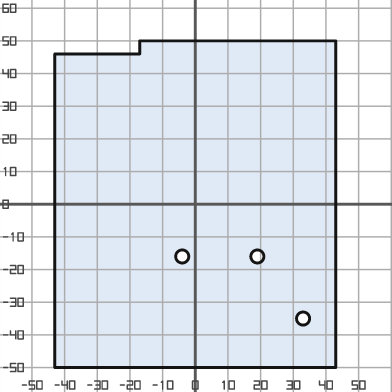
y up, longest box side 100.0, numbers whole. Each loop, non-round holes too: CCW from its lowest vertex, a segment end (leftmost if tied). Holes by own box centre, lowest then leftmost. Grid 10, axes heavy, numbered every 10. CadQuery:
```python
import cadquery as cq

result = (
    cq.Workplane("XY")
    .moveTo(-43.0, -50.0)
    .lineTo(43.0, -50.0)
    .lineTo(43.0, 50.0)
    .lineTo(-17.0, 50.0)
    .lineTo(-17.0, 46.0)
    .lineTo(-43.0, 46.0)
    .close()
    .moveTo(33.0, -35.0)
    .circle(2.0)
    .moveTo(-4.0, -16.0)
    .circle(2.0)
    .moveTo(19.0, -16.0)
    .circle(2.0)
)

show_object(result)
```